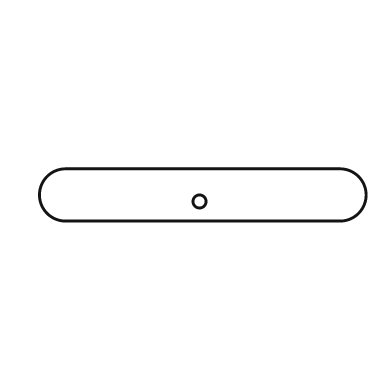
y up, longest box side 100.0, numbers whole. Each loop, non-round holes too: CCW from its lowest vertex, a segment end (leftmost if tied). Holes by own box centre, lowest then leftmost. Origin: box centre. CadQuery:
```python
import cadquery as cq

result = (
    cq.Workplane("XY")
    .moveTo(-42.0, -8.0)
    .lineTo(42.0, -8.0)
    .threePointArc((50.0, 0.0), (42.0, 8.0))
    .lineTo(-42.0, 8.0)
    .threePointArc((-50.0, 0.0), (-42.0, -8.0))
    .close()
    .moveTo(-1.0, -2.0)
    .circle(2.0)
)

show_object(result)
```